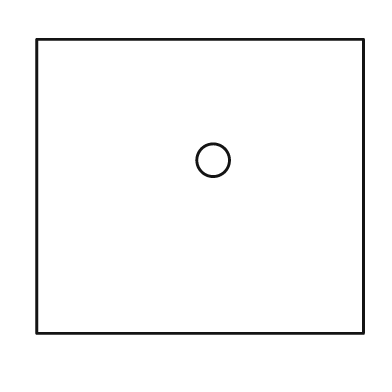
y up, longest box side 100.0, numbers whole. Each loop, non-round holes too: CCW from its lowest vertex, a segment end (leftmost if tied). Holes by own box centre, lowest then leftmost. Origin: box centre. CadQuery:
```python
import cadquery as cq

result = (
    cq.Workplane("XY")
    .moveTo(-50.0, -45.0)
    .lineTo(50.0, -45.0)
    .lineTo(50.0, 45.0)
    .lineTo(-50.0, 45.0)
    .close()
    .moveTo(4.0, 8.0)
    .circle(5.0)
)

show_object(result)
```